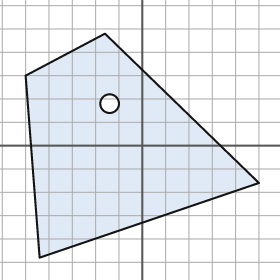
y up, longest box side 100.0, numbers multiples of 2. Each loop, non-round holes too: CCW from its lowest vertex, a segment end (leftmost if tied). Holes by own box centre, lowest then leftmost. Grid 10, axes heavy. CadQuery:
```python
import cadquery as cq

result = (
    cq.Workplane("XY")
    .moveTo(-44.0, -48.0)
    .lineTo(50.0, -16.0)
    .lineTo(-16.0, 48.0)
    .lineTo(-50.0, 30.0)
    .close()
    .moveTo(-14.0, 18.0)
    .circle(4.0)
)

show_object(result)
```